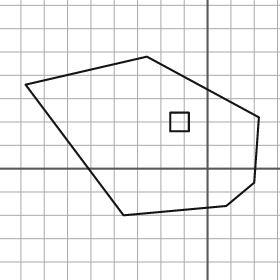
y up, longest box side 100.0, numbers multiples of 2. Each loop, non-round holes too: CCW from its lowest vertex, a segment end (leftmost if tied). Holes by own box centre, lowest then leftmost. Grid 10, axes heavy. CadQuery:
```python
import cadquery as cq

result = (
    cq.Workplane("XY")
    .moveTo(-36.0, -20.0)
    .lineTo(8.0, -16.0)
    .lineTo(20.0, -6.0)
    .lineTo(22.0, 22.0)
    .lineTo(-26.0, 48.0)
    .lineTo(-78.0, 36.0)
    .close()
    .moveTo(-16.0, 16.0)
    .lineTo(-8.0, 16.0)
    .lineTo(-8.0, 24.0)
    .lineTo(-16.0, 24.0)
    .close()
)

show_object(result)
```